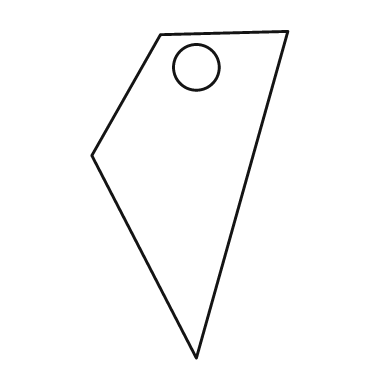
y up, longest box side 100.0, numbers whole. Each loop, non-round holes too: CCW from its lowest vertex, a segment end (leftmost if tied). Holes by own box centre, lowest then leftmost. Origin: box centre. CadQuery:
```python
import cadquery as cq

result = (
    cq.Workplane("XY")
    .moveTo(2.0, -50.0)
    .lineTo(30.0, 50.0)
    .lineTo(-9.0, 49.0)
    .lineTo(-30.0, 12.0)
    .close()
    .moveTo(2.0, 39.0)
    .circle(7.0)
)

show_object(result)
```